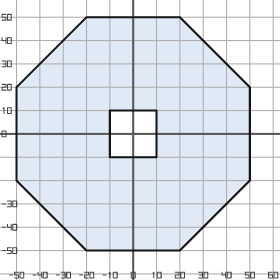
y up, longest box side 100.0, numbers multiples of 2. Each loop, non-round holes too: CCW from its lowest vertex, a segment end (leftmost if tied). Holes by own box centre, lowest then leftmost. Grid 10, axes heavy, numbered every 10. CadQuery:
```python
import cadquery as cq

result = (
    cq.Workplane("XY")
    .moveTo(-20.0, -50.0)
    .lineTo(20.0, -50.0)
    .lineTo(50.0, -20.0)
    .lineTo(50.0, 20.0)
    .lineTo(20.0, 50.0)
    .lineTo(-20.0, 50.0)
    .lineTo(-50.0, 20.0)
    .lineTo(-50.0, -20.0)
    .close()
    .moveTo(-10.0, -10.0)
    .lineTo(10.0, -10.0)
    .lineTo(10.0, 10.0)
    .lineTo(-10.0, 10.0)
    .close()
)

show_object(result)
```